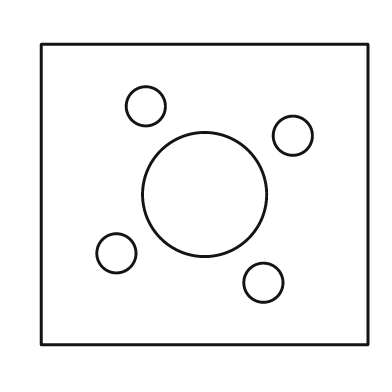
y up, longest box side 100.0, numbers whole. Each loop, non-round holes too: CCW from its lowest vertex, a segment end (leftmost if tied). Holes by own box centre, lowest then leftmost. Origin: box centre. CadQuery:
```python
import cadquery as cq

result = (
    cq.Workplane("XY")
    .moveTo(-50.0, -46.0)
    .lineTo(50.0, -46.0)
    .lineTo(50.0, 46.0)
    .lineTo(-50.0, 46.0)
    .close()
    .moveTo(18.0, -27.0)
    .circle(6.0)
    .moveTo(-27.0, -18.0)
    .circle(6.0)
    .moveTo(0.0, 0.0)
    .circle(19.0)
    .moveTo(27.0, 18.0)
    .circle(6.0)
    .moveTo(-18.0, 27.0)
    .circle(6.0)
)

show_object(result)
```